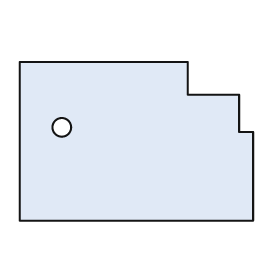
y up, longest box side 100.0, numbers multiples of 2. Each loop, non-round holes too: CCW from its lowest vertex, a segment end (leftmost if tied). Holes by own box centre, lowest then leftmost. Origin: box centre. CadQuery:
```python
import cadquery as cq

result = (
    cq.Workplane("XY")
    .moveTo(-50.0, -34.0)
    .lineTo(50.0, -34.0)
    .lineTo(50.0, 4.0)
    .lineTo(44.0, 4.0)
    .lineTo(44.0, 20.0)
    .lineTo(22.0, 20.0)
    .lineTo(22.0, 34.0)
    .lineTo(-50.0, 34.0)
    .close()
    .moveTo(-32.0, 6.0)
    .circle(4.0)
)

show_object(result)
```